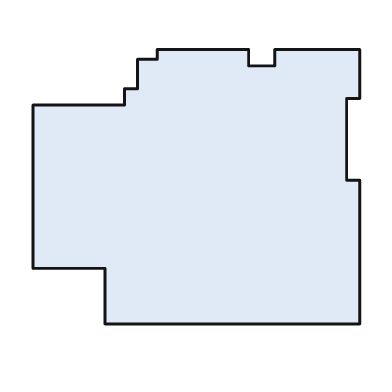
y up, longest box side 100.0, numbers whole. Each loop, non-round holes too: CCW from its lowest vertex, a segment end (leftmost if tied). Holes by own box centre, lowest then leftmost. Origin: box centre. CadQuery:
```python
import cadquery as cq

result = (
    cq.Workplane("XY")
    .moveTo(-28.0, -42.0)
    .lineTo(50.0, -42.0)
    .lineTo(50.0, 2.0)
    .lineTo(46.0, 2.0)
    .lineTo(46.0, 27.0)
    .lineTo(50.0, 27.0)
    .lineTo(50.0, 42.0)
    .lineTo(24.0, 42.0)
    .lineTo(24.0, 37.0)
    .lineTo(16.0, 37.0)
    .lineTo(16.0, 42.0)
    .lineTo(-12.0, 42.0)
    .lineTo(-12.0, 39.0)
    .lineTo(-18.0, 39.0)
    .lineTo(-18.0, 30.0)
    .lineTo(-22.0, 30.0)
    .lineTo(-22.0, 25.0)
    .lineTo(-50.0, 25.0)
    .lineTo(-50.0, -25.0)
    .lineTo(-28.0, -25.0)
    .close()
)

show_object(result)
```